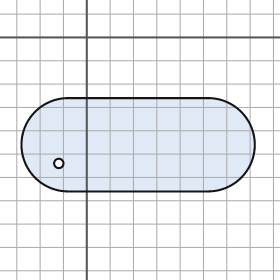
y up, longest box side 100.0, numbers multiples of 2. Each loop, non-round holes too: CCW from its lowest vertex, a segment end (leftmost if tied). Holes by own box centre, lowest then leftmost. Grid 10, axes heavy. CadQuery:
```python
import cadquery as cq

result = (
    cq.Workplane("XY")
    .moveTo(-8.0, -66.0)
    .lineTo(52.0, -66.0)
    .threePointArc((72.0, -46.0), (52.0, -26.0))
    .lineTo(-8.0, -26.0)
    .threePointArc((-28.0, -46.0), (-8.0, -66.0))
    .close()
    .moveTo(-12.0, -54.0)
    .circle(2.0)
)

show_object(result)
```